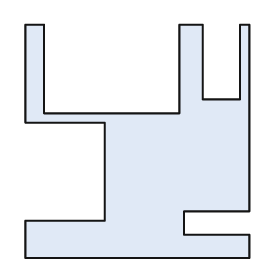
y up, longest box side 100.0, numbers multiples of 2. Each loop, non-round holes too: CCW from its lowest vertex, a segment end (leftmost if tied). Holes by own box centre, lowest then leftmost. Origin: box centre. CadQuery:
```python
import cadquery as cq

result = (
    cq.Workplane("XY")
    .moveTo(-48.0, -50.0)
    .lineTo(48.0, -50.0)
    .lineTo(48.0, -40.0)
    .lineTo(20.0, -40.0)
    .lineTo(20.0, -30.0)
    .lineTo(48.0, -30.0)
    .lineTo(48.0, 50.0)
    .lineTo(44.0, 50.0)
    .lineTo(44.0, 18.0)
    .lineTo(28.0, 18.0)
    .lineTo(28.0, 50.0)
    .lineTo(18.0, 50.0)
    .lineTo(18.0, 12.0)
    .lineTo(-40.0, 12.0)
    .lineTo(-40.0, 50.0)
    .lineTo(-48.0, 50.0)
    .lineTo(-48.0, 8.0)
    .lineTo(-14.0, 8.0)
    .lineTo(-14.0, -34.0)
    .lineTo(-48.0, -34.0)
    .close()
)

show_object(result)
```